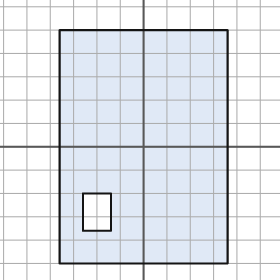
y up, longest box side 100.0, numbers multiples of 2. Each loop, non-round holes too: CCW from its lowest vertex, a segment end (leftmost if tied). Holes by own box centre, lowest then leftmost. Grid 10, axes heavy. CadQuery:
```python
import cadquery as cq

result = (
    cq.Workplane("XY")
    .moveTo(-36.0, -50.0)
    .lineTo(36.0, -50.0)
    .lineTo(36.0, 50.0)
    .lineTo(-36.0, 50.0)
    .close()
    .moveTo(-26.0, -36.0)
    .lineTo(-14.0, -36.0)
    .lineTo(-14.0, -20.0)
    .lineTo(-26.0, -20.0)
    .close()
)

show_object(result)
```